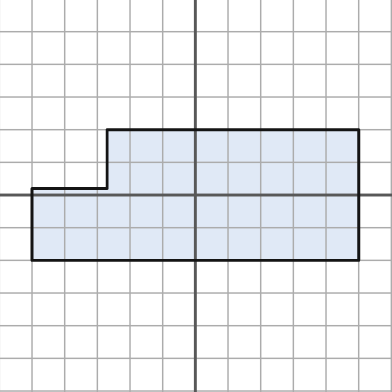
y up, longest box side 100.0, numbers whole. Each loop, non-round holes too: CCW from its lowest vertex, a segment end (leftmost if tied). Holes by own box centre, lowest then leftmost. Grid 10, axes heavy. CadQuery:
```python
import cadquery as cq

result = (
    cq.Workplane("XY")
    .moveTo(-50.0, -20.0)
    .lineTo(50.0, -20.0)
    .lineTo(50.0, 20.0)
    .lineTo(-27.0, 20.0)
    .lineTo(-27.0, 2.0)
    .lineTo(-50.0, 2.0)
    .close()
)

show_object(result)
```